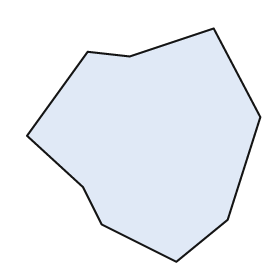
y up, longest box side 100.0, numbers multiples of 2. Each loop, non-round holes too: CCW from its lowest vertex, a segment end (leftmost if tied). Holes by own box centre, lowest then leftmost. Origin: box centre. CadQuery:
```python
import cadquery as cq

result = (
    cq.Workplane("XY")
    .moveTo(14.0, -50.0)
    .lineTo(36.0, -32.0)
    .lineTo(50.0, 12.0)
    .lineTo(30.0, 50.0)
    .lineTo(-6.0, 38.0)
    .lineTo(-24.0, 40.0)
    .lineTo(-50.0, 4.0)
    .lineTo(-26.0, -18.0)
    .lineTo(-18.0, -34.0)
    .close()
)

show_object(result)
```